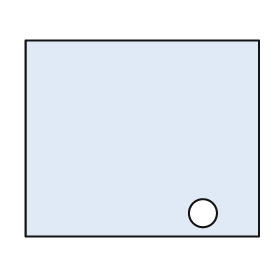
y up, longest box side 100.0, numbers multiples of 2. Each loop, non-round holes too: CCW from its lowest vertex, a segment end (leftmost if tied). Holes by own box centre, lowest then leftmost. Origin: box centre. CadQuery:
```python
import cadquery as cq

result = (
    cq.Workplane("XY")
    .moveTo(-50.0, -42.0)
    .lineTo(50.0, -42.0)
    .lineTo(50.0, 42.0)
    .lineTo(-50.0, 42.0)
    .close()
    .moveTo(26.0, -32.0)
    .circle(6.0)
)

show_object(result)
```